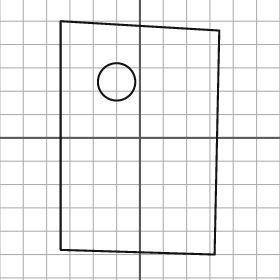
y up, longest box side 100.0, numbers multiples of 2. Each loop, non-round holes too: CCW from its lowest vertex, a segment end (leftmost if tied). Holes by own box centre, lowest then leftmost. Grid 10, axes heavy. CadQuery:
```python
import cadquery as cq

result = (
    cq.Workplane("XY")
    .moveTo(32.0, -50.0)
    .lineTo(34.0, 46.0)
    .lineTo(-34.0, 50.0)
    .lineTo(-34.0, -48.0)
    .close()
    .moveTo(-10.0, 24.0)
    .circle(8.0)
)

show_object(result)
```